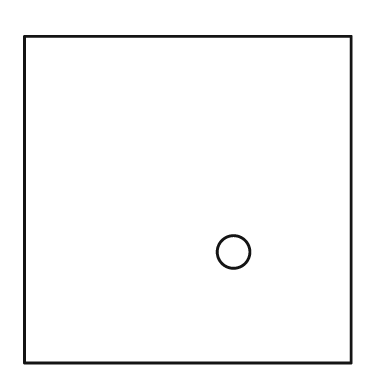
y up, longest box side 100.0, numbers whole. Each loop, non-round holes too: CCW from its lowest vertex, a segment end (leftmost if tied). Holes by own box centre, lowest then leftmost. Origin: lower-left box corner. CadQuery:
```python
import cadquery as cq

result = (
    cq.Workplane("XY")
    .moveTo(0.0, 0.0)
    .lineTo(100.0, 0.0)
    .lineTo(100.0, 100.0)
    .lineTo(0.0, 100.0)
    .close()
    .moveTo(64.0, 34.0)
    .circle(5.0)
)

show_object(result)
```